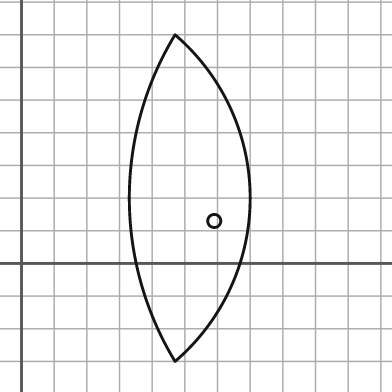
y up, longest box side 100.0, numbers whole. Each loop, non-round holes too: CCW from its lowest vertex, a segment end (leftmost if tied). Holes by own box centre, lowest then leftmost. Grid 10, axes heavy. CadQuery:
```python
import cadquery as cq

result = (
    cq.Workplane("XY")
    .moveTo(47.0, -30.0)
    .threePointArc((70.0, 20.0), (47.0, 70.0))
    .threePointArc((33.0, 20.0), (47.0, -30.0))
    .close()
    .moveTo(59.0, 13.0)
    .circle(2.0)
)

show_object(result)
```